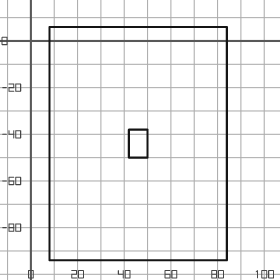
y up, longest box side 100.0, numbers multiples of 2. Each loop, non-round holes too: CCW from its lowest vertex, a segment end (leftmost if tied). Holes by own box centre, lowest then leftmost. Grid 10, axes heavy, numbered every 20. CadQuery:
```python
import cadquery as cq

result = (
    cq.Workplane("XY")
    .moveTo(8.0, -94.0)
    .lineTo(84.0, -94.0)
    .lineTo(84.0, 6.0)
    .lineTo(8.0, 6.0)
    .close()
    .moveTo(42.0, -50.0)
    .lineTo(50.0, -50.0)
    .lineTo(50.0, -38.0)
    .lineTo(42.0, -38.0)
    .close()
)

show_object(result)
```